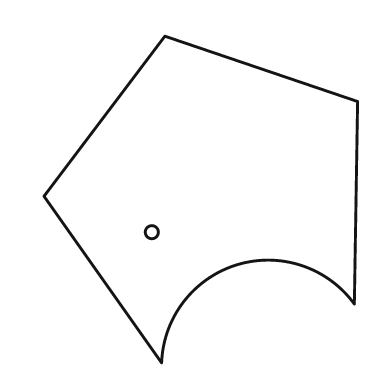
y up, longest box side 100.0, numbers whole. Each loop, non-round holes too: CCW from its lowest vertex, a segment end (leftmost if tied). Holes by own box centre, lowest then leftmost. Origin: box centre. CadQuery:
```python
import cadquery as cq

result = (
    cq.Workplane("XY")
    .moveTo(-12.0, -50.0)
    .threePointArc((11.0, -20.0), (47.0, -32.0))
    .lineTo(48.0, 30.0)
    .lineTo(-11.0, 50.0)
    .lineTo(-48.0, 1.0)
    .close()
    .moveTo(-15.0, -10.0)
    .circle(2.0)
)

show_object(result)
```